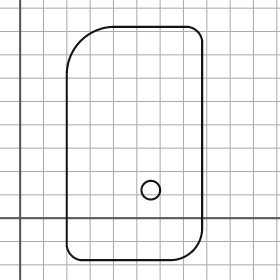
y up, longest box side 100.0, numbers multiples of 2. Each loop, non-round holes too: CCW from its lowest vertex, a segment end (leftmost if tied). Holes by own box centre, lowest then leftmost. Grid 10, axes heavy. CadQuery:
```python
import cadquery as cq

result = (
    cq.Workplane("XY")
    .moveTo(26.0, -18.0)
    .lineTo(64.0, -18.0)
    .threePointArc((74.0, -14.0), (78.0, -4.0))
    .lineTo(78.0, 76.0)
    .threePointArc((76.0, 80.0), (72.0, 82.0))
    .lineTo(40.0, 82.0)
    .threePointArc((26.0, 76.0), (20.0, 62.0))
    .lineTo(20.0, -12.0)
    .threePointArc((22.0, -16.0), (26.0, -18.0))
    .close()
    .moveTo(56.0, 12.0)
    .circle(4.0)
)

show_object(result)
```